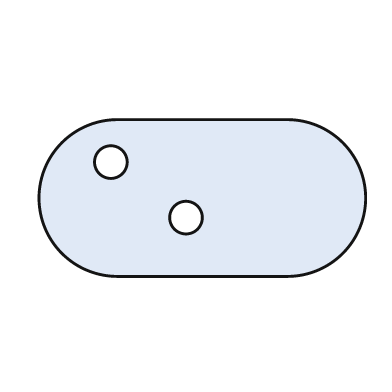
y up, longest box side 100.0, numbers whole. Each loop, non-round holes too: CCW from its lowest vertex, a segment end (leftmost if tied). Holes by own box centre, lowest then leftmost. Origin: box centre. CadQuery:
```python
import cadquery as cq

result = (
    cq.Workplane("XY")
    .moveTo(-26.0, -24.0)
    .lineTo(26.0, -24.0)
    .threePointArc((50.0, 0.0), (26.0, 24.0))
    .lineTo(-26.0, 24.0)
    .threePointArc((-50.0, 0.0), (-26.0, -24.0))
    .close()
    .moveTo(-5.0, -6.0)
    .circle(5.0)
    .moveTo(-28.0, 11.0)
    .circle(5.0)
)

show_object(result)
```